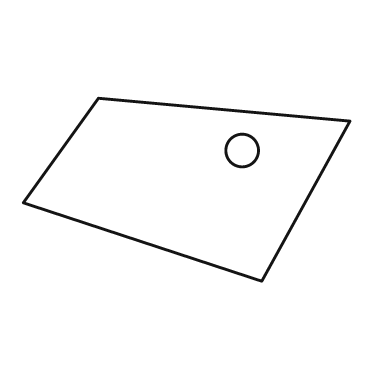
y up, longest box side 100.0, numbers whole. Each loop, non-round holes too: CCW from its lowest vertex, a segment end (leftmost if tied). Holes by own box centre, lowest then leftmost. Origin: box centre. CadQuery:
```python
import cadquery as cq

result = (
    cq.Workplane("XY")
    .moveTo(23.0, -28.0)
    .lineTo(50.0, 21.0)
    .lineTo(-27.0, 28.0)
    .lineTo(-50.0, -4.0)
    .close()
    .moveTo(17.0, 12.0)
    .circle(5.0)
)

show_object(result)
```